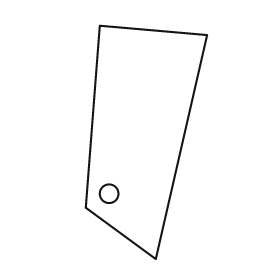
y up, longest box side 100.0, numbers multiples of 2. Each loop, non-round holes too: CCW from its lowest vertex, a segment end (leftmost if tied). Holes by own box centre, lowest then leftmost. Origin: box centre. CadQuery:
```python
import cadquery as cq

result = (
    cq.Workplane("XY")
    .moveTo(4.0, -50.0)
    .lineTo(26.0, 46.0)
    .lineTo(-20.0, 50.0)
    .lineTo(-26.0, -28.0)
    .close()
    .moveTo(-16.0, -22.0)
    .circle(4.0)
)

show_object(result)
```